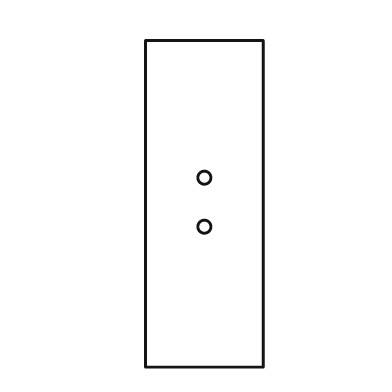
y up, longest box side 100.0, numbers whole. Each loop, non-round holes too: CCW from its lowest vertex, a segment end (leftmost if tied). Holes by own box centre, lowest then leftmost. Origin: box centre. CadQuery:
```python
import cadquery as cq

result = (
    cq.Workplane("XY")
    .moveTo(-18.0, -50.0)
    .lineTo(18.0, -50.0)
    .lineTo(18.0, 50.0)
    .lineTo(-18.0, 50.0)
    .close()
    .moveTo(0.0, -7.0)
    .circle(2.0)
    .moveTo(0.0, 8.0)
    .circle(2.0)
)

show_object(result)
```